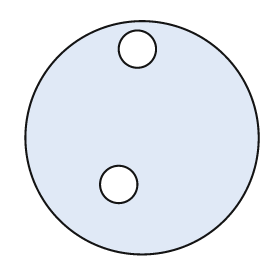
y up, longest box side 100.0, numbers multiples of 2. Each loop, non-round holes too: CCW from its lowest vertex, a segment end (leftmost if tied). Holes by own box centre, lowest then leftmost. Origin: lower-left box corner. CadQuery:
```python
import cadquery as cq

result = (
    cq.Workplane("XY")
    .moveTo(50.0, 50.0)
    .circle(50.0)
    .moveTo(40.0, 30.0)
    .circle(8.0)
    .moveTo(48.0, 88.0)
    .circle(8.0)
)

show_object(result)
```